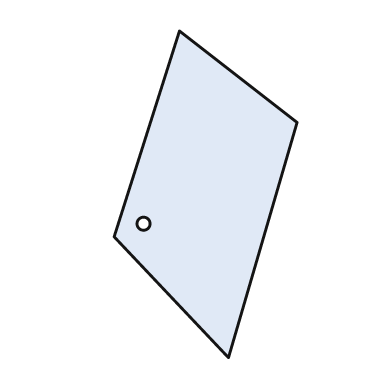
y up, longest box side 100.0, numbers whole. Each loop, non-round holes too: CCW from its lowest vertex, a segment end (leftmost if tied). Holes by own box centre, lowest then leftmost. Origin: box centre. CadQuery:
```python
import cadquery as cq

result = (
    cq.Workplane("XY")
    .moveTo(7.0, -50.0)
    .lineTo(28.0, 22.0)
    .lineTo(-8.0, 50.0)
    .lineTo(-28.0, -13.0)
    .close()
    .moveTo(-19.0, -9.0)
    .circle(2.0)
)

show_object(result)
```